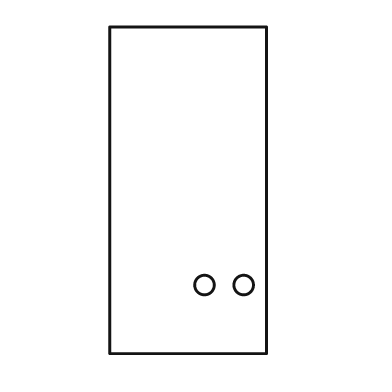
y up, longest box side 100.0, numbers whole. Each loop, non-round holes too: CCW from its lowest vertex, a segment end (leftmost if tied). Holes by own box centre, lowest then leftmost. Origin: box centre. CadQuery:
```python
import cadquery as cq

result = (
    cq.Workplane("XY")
    .moveTo(-24.0, -50.0)
    .lineTo(24.0, -50.0)
    .lineTo(24.0, 50.0)
    .lineTo(-24.0, 50.0)
    .close()
    .moveTo(5.0, -29.0)
    .circle(3.0)
    .moveTo(17.0, -29.0)
    .circle(3.0)
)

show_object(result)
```